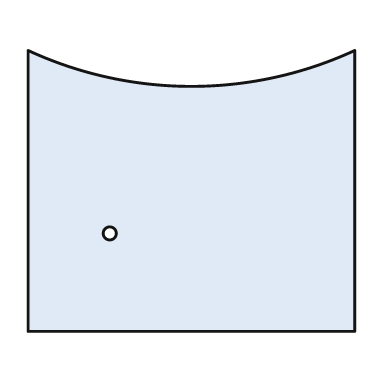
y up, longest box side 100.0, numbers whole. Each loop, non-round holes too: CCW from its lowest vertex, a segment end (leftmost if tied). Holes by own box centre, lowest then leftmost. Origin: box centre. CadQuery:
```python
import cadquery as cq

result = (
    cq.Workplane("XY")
    .moveTo(-50.0, -43.0)
    .lineTo(50.0, -43.0)
    .lineTo(50.0, 43.0)
    .threePointArc((0.0, 32.0), (-50.0, 43.0))
    .close()
    .moveTo(-25.0, -13.0)
    .circle(2.0)
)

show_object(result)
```